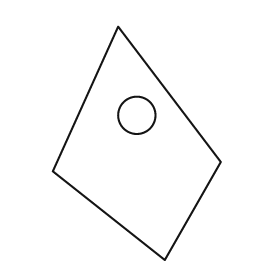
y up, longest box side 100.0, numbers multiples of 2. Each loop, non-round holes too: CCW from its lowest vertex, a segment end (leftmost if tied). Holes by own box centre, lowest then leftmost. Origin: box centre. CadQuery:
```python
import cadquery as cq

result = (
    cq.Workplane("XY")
    .moveTo(12.0, -50.0)
    .lineTo(36.0, -8.0)
    .lineTo(-8.0, 50.0)
    .lineTo(-36.0, -12.0)
    .close()
    .moveTo(0.0, 12.0)
    .circle(8.0)
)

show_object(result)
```